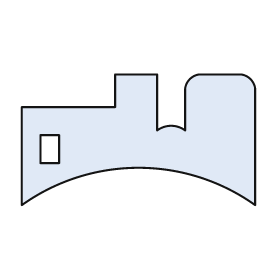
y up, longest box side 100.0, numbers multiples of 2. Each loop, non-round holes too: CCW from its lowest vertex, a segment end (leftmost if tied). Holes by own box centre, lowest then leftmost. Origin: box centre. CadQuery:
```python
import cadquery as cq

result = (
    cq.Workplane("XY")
    .moveTo(-50.0, -28.0)
    .threePointArc((0.0, -12.0), (50.0, -28.0))
    .lineTo(50.0, 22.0)
    .threePointArc((48.0, 26.0), (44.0, 28.0))
    .lineTo(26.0, 28.0)
    .threePointArc((22.0, 26.0), (20.0, 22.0))
    .lineTo(20.0, 4.0)
    .threePointArc((14.0, 6.0), (8.0, 4.0))
    .lineTo(8.0, 28.0)
    .lineTo(-10.0, 28.0)
    .lineTo(-10.0, 14.0)
    .lineTo(-50.0, 14.0)
    .close()
    .moveTo(-42.0, -10.0)
    .lineTo(-34.0, -10.0)
    .lineTo(-34.0, 2.0)
    .lineTo(-42.0, 2.0)
    .close()
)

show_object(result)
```